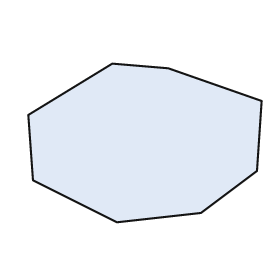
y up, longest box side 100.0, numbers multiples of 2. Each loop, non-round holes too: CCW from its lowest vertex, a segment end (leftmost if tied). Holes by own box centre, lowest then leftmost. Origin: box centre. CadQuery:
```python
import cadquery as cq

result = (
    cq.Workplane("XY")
    .moveTo(-12.0, -34.0)
    .lineTo(24.0, -30.0)
    .lineTo(48.0, -12.0)
    .lineTo(50.0, 18.0)
    .lineTo(10.0, 32.0)
    .lineTo(-14.0, 34.0)
    .lineTo(-50.0, 12.0)
    .lineTo(-48.0, -16.0)
    .close()
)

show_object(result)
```